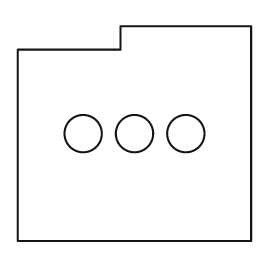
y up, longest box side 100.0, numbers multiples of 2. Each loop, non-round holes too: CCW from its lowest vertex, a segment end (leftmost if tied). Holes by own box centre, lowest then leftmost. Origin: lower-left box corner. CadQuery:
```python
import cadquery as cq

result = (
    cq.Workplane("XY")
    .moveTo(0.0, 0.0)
    .lineTo(100.0, 0.0)
    .lineTo(100.0, 92.0)
    .lineTo(44.0, 92.0)
    .lineTo(44.0, 82.0)
    .lineTo(0.0, 82.0)
    .close()
    .moveTo(28.0, 46.0)
    .circle(8.0)
    .moveTo(50.0, 46.0)
    .circle(8.0)
    .moveTo(72.0, 46.0)
    .circle(8.0)
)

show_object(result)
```